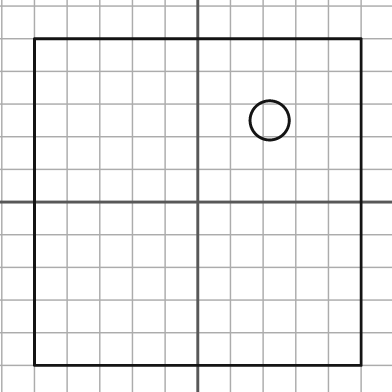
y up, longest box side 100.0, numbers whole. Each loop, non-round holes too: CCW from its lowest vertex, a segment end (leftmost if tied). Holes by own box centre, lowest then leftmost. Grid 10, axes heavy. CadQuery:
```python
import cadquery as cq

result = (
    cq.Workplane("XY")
    .moveTo(-50.0, -50.0)
    .lineTo(50.0, -50.0)
    .lineTo(50.0, 50.0)
    .lineTo(-50.0, 50.0)
    .close()
    .moveTo(22.0, 25.0)
    .circle(6.0)
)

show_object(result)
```